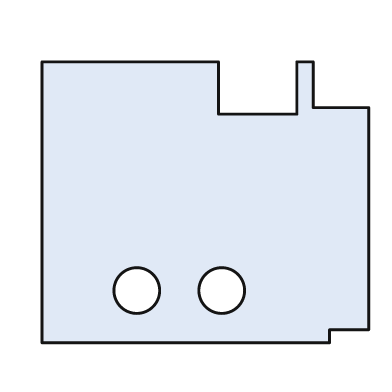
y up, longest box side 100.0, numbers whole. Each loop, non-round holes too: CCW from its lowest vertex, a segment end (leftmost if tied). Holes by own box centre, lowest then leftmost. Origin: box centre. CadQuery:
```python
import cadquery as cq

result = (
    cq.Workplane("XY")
    .moveTo(-50.0, -43.0)
    .lineTo(38.0, -43.0)
    .lineTo(38.0, -39.0)
    .lineTo(50.0, -39.0)
    .lineTo(50.0, 29.0)
    .lineTo(33.0, 29.0)
    .lineTo(33.0, 43.0)
    .lineTo(28.0, 43.0)
    .lineTo(28.0, 27.0)
    .lineTo(4.0, 27.0)
    .lineTo(4.0, 43.0)
    .lineTo(-50.0, 43.0)
    .close()
    .moveTo(-21.0, -27.0)
    .circle(7.0)
    .moveTo(5.0, -27.0)
    .circle(7.0)
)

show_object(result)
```